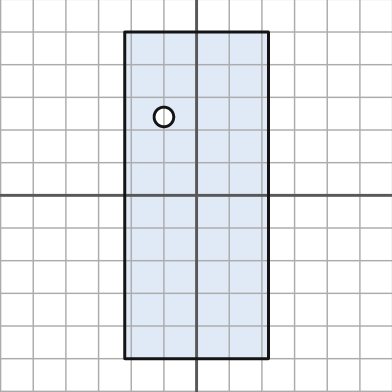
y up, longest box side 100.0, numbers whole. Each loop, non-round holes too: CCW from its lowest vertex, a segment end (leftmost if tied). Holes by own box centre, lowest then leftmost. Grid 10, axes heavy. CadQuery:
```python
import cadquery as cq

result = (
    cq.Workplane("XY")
    .moveTo(-22.0, -50.0)
    .lineTo(22.0, -50.0)
    .lineTo(22.0, 50.0)
    .lineTo(-22.0, 50.0)
    .close()
    .moveTo(-10.0, 24.0)
    .circle(3.0)
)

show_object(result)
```